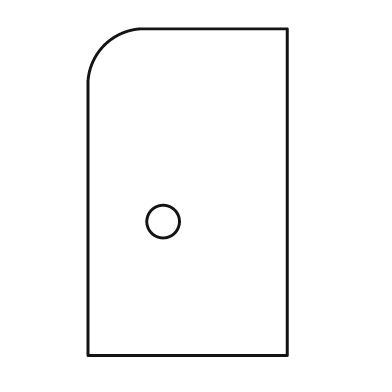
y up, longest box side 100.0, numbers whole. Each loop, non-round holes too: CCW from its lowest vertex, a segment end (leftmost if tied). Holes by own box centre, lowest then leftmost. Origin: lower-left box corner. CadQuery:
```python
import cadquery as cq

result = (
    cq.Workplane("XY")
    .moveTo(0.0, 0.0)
    .lineTo(61.0, 0.0)
    .lineTo(61.0, 100.0)
    .lineTo(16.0, 100.0)
    .threePointArc((5.0, 95.0), (0.0, 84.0))
    .close()
    .moveTo(23.0, 41.0)
    .circle(5.0)
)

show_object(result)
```